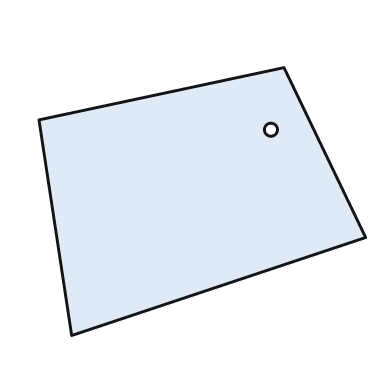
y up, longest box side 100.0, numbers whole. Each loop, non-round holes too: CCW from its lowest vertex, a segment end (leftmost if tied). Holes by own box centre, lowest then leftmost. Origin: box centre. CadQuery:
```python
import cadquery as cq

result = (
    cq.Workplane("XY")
    .moveTo(-40.0, -41.0)
    .lineTo(50.0, -11.0)
    .lineTo(25.0, 41.0)
    .lineTo(-50.0, 25.0)
    .close()
    .moveTo(21.0, 22.0)
    .circle(2.0)
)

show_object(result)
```